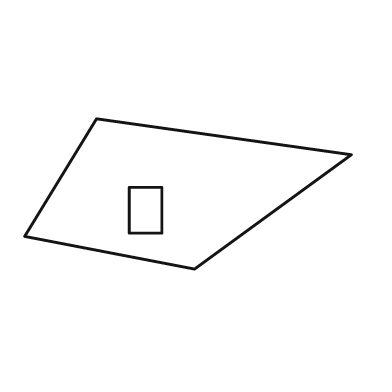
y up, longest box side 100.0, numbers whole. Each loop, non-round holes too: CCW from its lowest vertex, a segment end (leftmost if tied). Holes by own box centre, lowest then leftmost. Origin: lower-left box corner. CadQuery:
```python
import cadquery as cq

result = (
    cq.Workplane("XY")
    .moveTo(52.0, 0.0)
    .lineTo(100.0, 35.0)
    .lineTo(22.0, 46.0)
    .lineTo(0.0, 10.0)
    .close()
    .moveTo(32.0, 11.0)
    .lineTo(42.0, 11.0)
    .lineTo(42.0, 25.0)
    .lineTo(32.0, 25.0)
    .close()
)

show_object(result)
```